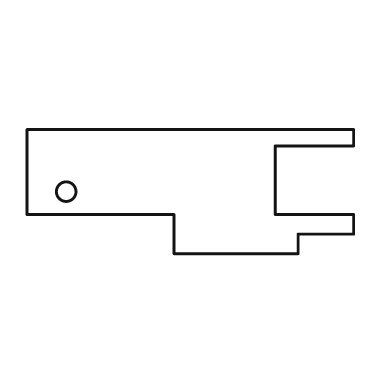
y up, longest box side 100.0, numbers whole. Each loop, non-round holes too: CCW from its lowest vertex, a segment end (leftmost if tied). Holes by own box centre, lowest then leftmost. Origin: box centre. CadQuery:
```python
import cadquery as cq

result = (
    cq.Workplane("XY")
    .moveTo(-5.0, -19.0)
    .lineTo(33.0, -19.0)
    .lineTo(33.0, -13.0)
    .lineTo(50.0, -13.0)
    .lineTo(50.0, -7.0)
    .lineTo(26.0, -7.0)
    .lineTo(26.0, 14.0)
    .lineTo(50.0, 14.0)
    .lineTo(50.0, 19.0)
    .lineTo(-50.0, 19.0)
    .lineTo(-50.0, -7.0)
    .lineTo(-5.0, -7.0)
    .close()
    .moveTo(-38.0, 0.0)
    .circle(3.0)
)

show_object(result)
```